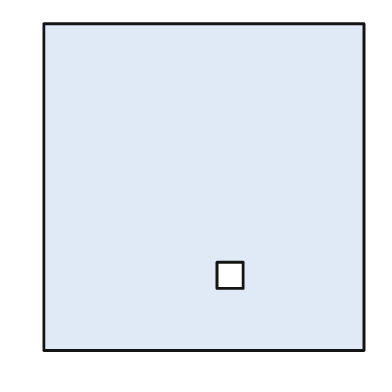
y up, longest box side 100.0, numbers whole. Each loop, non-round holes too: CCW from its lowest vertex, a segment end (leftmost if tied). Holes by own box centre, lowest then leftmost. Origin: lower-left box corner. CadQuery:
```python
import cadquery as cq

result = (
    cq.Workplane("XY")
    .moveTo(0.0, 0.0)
    .lineTo(98.0, 0.0)
    .lineTo(98.0, 100.0)
    .lineTo(0.0, 100.0)
    .close()
    .moveTo(53.0, 19.0)
    .lineTo(61.0, 19.0)
    .lineTo(61.0, 27.0)
    .lineTo(53.0, 27.0)
    .close()
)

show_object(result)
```